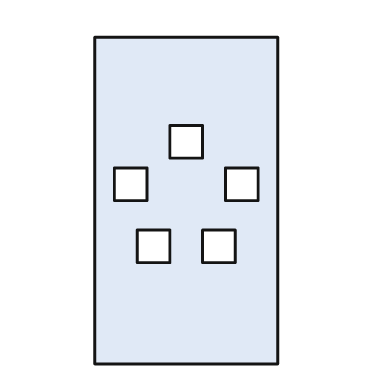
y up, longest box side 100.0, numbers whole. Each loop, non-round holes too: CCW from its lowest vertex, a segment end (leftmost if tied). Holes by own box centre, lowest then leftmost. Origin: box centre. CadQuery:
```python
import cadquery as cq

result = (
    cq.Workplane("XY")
    .moveTo(-28.0, -50.0)
    .lineTo(28.0, -50.0)
    .lineTo(28.0, 50.0)
    .lineTo(-28.0, 50.0)
    .close()
    .moveTo(-15.0, -19.0)
    .lineTo(-5.0, -19.0)
    .lineTo(-5.0, -9.0)
    .lineTo(-15.0, -9.0)
    .close()
    .moveTo(5.0, -19.0)
    .lineTo(15.0, -19.0)
    .lineTo(15.0, -9.0)
    .lineTo(5.0, -9.0)
    .close()
    .moveTo(-22.0, 0.0)
    .lineTo(-12.0, 0.0)
    .lineTo(-12.0, 10.0)
    .lineTo(-22.0, 10.0)
    .close()
    .moveTo(12.0, 0.0)
    .lineTo(22.0, 0.0)
    .lineTo(22.0, 10.0)
    .lineTo(12.0, 10.0)
    .close()
    .moveTo(-5.0, 13.0)
    .lineTo(5.0, 13.0)
    .lineTo(5.0, 23.0)
    .lineTo(-5.0, 23.0)
    .close()
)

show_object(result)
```